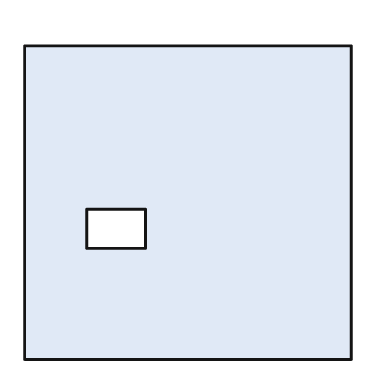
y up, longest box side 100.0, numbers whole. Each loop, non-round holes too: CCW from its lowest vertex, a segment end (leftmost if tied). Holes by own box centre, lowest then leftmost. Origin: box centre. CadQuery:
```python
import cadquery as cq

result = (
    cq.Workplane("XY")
    .moveTo(-50.0, -48.0)
    .lineTo(50.0, -48.0)
    .lineTo(50.0, 48.0)
    .lineTo(-50.0, 48.0)
    .close()
    .moveTo(-31.0, -14.0)
    .lineTo(-13.0, -14.0)
    .lineTo(-13.0, -2.0)
    .lineTo(-31.0, -2.0)
    .close()
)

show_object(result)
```